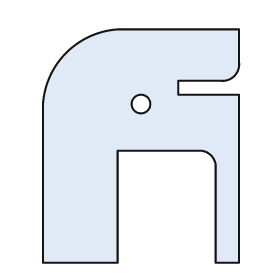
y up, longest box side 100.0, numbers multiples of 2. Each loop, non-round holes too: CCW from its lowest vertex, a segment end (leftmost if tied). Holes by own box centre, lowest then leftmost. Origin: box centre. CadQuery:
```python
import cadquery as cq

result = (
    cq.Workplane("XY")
    .moveTo(-42.0, -50.0)
    .lineTo(-10.0, -50.0)
    .lineTo(-10.0, -2.0)
    .lineTo(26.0, -2.0)
    .threePointArc((30.0, -4.0), (32.0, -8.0))
    .lineTo(32.0, -50.0)
    .lineTo(42.0, -50.0)
    .lineTo(42.0, 22.0)
    .lineTo(16.0, 22.0)
    .lineTo(16.0, 28.0)
    .lineTo(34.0, 28.0)
    .threePointArc((40.0, 30.0), (42.0, 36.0))
    .lineTo(42.0, 50.0)
    .lineTo(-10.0, 50.0)
    .threePointArc((-32.0, 40.0), (-42.0, 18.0))
    .close()
    .moveTo(0.0, 18.0)
    .circle(4.0)
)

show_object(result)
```